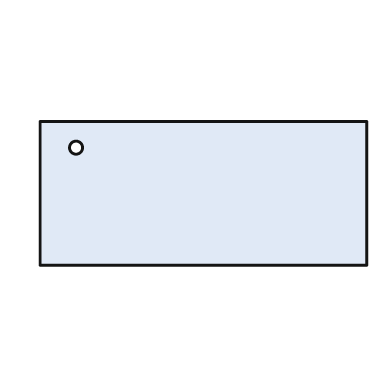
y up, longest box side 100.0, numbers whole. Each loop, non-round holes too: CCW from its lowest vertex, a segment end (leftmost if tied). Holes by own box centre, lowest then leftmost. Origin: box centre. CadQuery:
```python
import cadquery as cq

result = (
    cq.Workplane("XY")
    .moveTo(-50.0, -22.0)
    .lineTo(50.0, -22.0)
    .lineTo(50.0, 22.0)
    .lineTo(-50.0, 22.0)
    .close()
    .moveTo(-39.0, 14.0)
    .circle(2.0)
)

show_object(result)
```